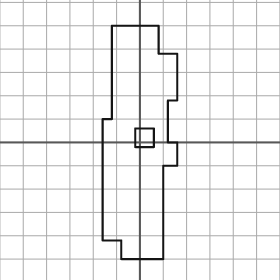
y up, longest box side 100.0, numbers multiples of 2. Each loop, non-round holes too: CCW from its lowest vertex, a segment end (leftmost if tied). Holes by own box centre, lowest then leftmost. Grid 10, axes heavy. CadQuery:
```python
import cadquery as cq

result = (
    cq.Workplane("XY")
    .moveTo(-8.0, -50.0)
    .lineTo(10.0, -50.0)
    .lineTo(10.0, -10.0)
    .lineTo(16.0, -10.0)
    .lineTo(16.0, 0.0)
    .lineTo(12.0, 0.0)
    .lineTo(12.0, 18.0)
    .lineTo(16.0, 18.0)
    .lineTo(16.0, 38.0)
    .lineTo(8.0, 38.0)
    .lineTo(8.0, 50.0)
    .lineTo(-12.0, 50.0)
    .lineTo(-12.0, 10.0)
    .lineTo(-16.0, 10.0)
    .lineTo(-16.0, -42.0)
    .lineTo(-8.0, -42.0)
    .close()
    .moveTo(-2.0, -2.0)
    .lineTo(6.0, -2.0)
    .lineTo(6.0, 6.0)
    .lineTo(-2.0, 6.0)
    .close()
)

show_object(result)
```